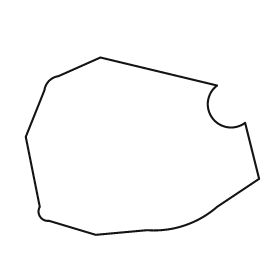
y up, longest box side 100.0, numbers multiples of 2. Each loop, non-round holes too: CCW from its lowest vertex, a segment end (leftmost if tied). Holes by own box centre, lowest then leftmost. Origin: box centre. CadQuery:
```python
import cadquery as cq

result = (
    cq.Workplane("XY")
    .moveTo(-20.0, -38.0)
    .lineTo(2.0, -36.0)
    .threePointArc((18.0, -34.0), (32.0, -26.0))
    .lineTo(50.0, -14.0)
    .lineTo(44.0, 10.0)
    .threePointArc((30.0, 12.0), (32.0, 26.0))
    .lineTo(-18.0, 38.0)
    .lineTo(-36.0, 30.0)
    .threePointArc((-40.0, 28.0), (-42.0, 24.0))
    .lineTo(-50.0, 4.0)
    .lineTo(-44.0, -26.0)
    .threePointArc((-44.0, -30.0), (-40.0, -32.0))
    .close()
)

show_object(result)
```